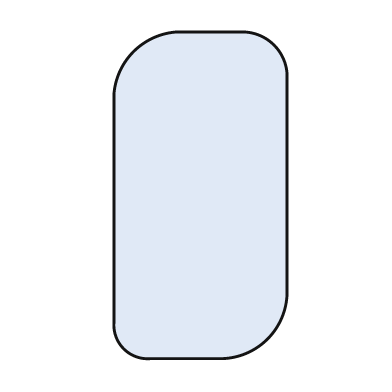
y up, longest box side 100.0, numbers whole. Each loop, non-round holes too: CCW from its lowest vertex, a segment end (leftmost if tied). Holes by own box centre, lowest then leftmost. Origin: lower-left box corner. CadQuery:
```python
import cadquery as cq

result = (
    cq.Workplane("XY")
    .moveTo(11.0, 0.0)
    .lineTo(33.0, 0.0)
    .threePointArc((47.0, 6.0), (53.0, 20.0))
    .lineTo(53.0, 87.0)
    .threePointArc((49.0, 96.0), (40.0, 100.0))
    .lineTo(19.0, 100.0)
    .threePointArc((6.0, 94.0), (0.0, 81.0))
    .lineTo(0.0, 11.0)
    .threePointArc((3.0, 3.0), (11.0, 0.0))
    .close()
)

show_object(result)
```